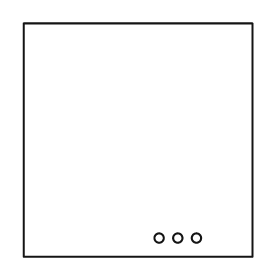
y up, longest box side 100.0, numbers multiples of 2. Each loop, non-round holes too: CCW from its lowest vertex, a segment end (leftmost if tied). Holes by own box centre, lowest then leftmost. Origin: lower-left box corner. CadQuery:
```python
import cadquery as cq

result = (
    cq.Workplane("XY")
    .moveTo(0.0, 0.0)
    .lineTo(98.0, 0.0)
    .lineTo(98.0, 100.0)
    .lineTo(0.0, 100.0)
    .close()
    .moveTo(58.0, 8.0)
    .circle(2.0)
    .moveTo(66.0, 8.0)
    .circle(2.0)
    .moveTo(74.0, 8.0)
    .circle(2.0)
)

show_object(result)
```